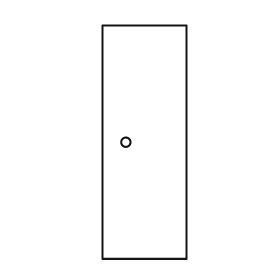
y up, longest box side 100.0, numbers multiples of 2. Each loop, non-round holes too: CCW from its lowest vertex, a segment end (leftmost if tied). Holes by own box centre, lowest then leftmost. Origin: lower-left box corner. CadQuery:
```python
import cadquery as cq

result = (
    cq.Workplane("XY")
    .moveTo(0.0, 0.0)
    .lineTo(36.0, 0.0)
    .lineTo(36.0, 100.0)
    .lineTo(0.0, 100.0)
    .close()
    .moveTo(10.0, 50.0)
    .circle(2.0)
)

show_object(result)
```